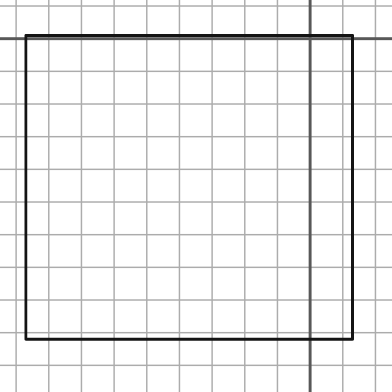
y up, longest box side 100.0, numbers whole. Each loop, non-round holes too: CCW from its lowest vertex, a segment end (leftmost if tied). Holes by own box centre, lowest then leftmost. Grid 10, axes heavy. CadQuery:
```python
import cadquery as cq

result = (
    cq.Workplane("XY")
    .moveTo(-87.0, -92.0)
    .lineTo(13.0, -92.0)
    .lineTo(13.0, 1.0)
    .lineTo(-87.0, 1.0)
    .close()
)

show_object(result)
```